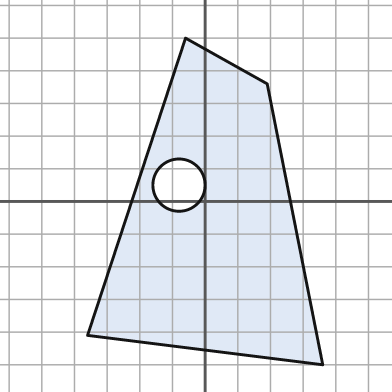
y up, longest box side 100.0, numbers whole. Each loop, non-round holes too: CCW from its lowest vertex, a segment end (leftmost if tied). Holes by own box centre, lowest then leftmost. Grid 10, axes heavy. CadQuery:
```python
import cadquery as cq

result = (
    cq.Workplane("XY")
    .moveTo(36.0, -50.0)
    .lineTo(19.0, 36.0)
    .lineTo(-6.0, 50.0)
    .lineTo(-36.0, -41.0)
    .close()
    .moveTo(-8.0, 5.0)
    .circle(8.0)
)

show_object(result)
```